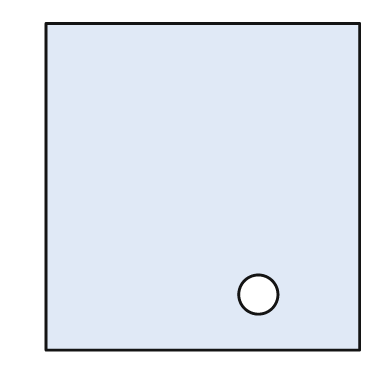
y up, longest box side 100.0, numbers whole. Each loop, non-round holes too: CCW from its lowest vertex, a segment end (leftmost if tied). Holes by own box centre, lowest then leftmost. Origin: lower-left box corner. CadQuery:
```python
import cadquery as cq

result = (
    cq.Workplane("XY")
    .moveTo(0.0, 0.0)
    .lineTo(96.0, 0.0)
    .lineTo(96.0, 100.0)
    .lineTo(0.0, 100.0)
    .close()
    .moveTo(65.0, 17.0)
    .circle(6.0)
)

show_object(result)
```